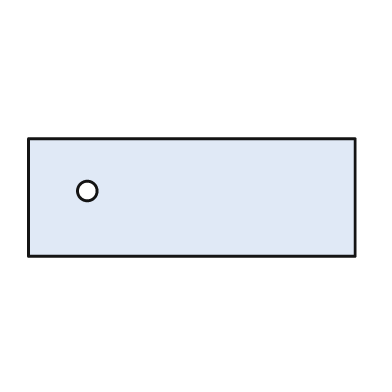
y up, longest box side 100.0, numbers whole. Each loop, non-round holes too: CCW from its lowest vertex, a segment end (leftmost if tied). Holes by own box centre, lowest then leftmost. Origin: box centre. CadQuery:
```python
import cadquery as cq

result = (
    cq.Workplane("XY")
    .moveTo(-50.0, -18.0)
    .lineTo(50.0, -18.0)
    .lineTo(50.0, 18.0)
    .lineTo(-50.0, 18.0)
    .close()
    .moveTo(-32.0, 2.0)
    .circle(3.0)
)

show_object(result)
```